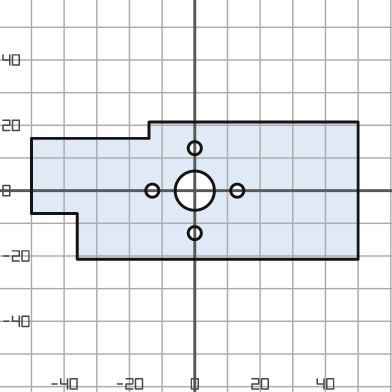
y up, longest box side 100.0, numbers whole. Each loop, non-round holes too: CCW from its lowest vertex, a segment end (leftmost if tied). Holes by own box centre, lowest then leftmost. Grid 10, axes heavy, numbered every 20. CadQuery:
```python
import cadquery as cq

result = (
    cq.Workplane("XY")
    .moveTo(-36.0, -21.0)
    .lineTo(50.0, -21.0)
    .lineTo(50.0, 21.0)
    .lineTo(-14.0, 21.0)
    .lineTo(-14.0, 16.0)
    .lineTo(-50.0, 16.0)
    .lineTo(-50.0, -7.0)
    .lineTo(-36.0, -7.0)
    .close()
    .moveTo(0.0, -13.0)
    .circle(2.0)
    .moveTo(-13.0, 0.0)
    .circle(2.0)
    .moveTo(0.0, 0.0)
    .circle(6.0)
    .moveTo(13.0, 0.0)
    .circle(2.0)
    .moveTo(0.0, 13.0)
    .circle(2.0)
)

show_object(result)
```